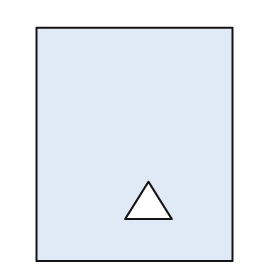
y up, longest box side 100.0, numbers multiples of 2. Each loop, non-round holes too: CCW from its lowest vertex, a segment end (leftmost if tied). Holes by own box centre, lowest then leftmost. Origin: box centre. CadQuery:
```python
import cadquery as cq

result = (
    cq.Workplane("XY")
    .moveTo(-42.0, -50.0)
    .lineTo(42.0, -50.0)
    .lineTo(42.0, 50.0)
    .lineTo(-42.0, 50.0)
    .close()
    .moveTo(-4.0, -32.0)
    .lineTo(16.0, -32.0)
    .lineTo(6.0, -16.0)
    .close()
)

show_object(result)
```